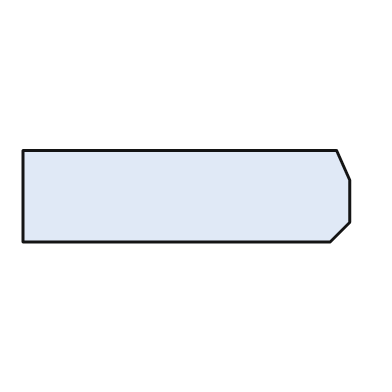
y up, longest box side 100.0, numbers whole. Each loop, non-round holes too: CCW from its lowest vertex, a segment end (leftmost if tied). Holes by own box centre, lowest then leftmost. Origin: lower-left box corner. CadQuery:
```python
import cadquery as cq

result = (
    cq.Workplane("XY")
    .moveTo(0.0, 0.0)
    .lineTo(94.0, 0.0)
    .lineTo(100.0, 6.0)
    .lineTo(100.0, 19.0)
    .lineTo(96.0, 28.0)
    .lineTo(0.0, 28.0)
    .close()
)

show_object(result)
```